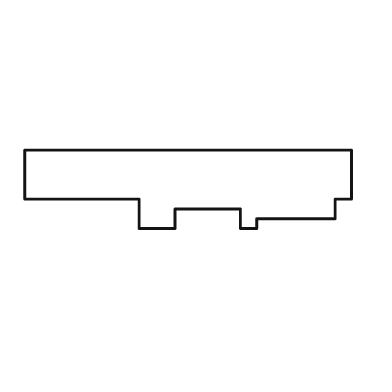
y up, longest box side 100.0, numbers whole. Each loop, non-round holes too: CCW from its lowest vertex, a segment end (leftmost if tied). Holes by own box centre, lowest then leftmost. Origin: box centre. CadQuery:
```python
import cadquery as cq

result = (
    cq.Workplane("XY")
    .moveTo(-15.0, -12.0)
    .lineTo(-4.0, -12.0)
    .lineTo(-4.0, -6.0)
    .lineTo(16.0, -6.0)
    .lineTo(16.0, -12.0)
    .lineTo(21.0, -12.0)
    .lineTo(21.0, -9.0)
    .lineTo(45.0, -9.0)
    .lineTo(45.0, -3.0)
    .lineTo(50.0, -3.0)
    .lineTo(50.0, 12.0)
    .lineTo(-50.0, 12.0)
    .lineTo(-50.0, -3.0)
    .lineTo(-15.0, -3.0)
    .close()
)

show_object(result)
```